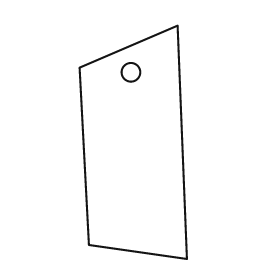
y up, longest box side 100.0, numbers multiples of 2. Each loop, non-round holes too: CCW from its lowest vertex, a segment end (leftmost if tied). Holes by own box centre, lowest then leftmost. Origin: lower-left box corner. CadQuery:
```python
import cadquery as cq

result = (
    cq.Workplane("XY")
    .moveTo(46.0, 0.0)
    .lineTo(42.0, 100.0)
    .lineTo(0.0, 82.0)
    .lineTo(4.0, 6.0)
    .close()
    .moveTo(22.0, 80.0)
    .circle(4.0)
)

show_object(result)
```